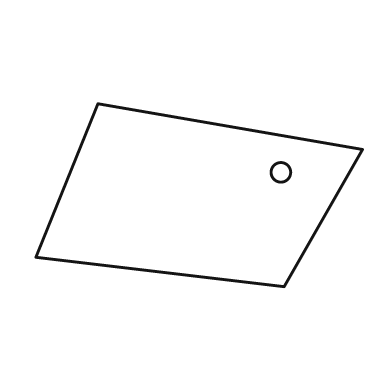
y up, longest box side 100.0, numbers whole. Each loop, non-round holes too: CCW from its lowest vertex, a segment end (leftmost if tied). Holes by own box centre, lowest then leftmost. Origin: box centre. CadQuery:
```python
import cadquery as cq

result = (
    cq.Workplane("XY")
    .moveTo(26.0, -28.0)
    .lineTo(50.0, 14.0)
    .lineTo(-31.0, 28.0)
    .lineTo(-50.0, -19.0)
    .close()
    .moveTo(25.0, 7.0)
    .circle(3.0)
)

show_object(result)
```